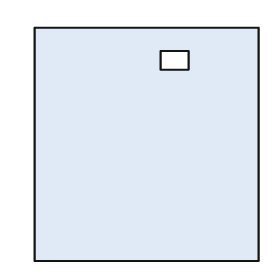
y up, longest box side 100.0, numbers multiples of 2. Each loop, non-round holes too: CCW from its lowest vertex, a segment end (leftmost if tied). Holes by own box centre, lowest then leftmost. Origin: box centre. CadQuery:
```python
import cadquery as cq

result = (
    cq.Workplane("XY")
    .moveTo(-48.0, -50.0)
    .lineTo(48.0, -50.0)
    .lineTo(48.0, 50.0)
    .lineTo(-48.0, 50.0)
    .close()
    .moveTo(6.0, 32.0)
    .lineTo(18.0, 32.0)
    .lineTo(18.0, 40.0)
    .lineTo(6.0, 40.0)
    .close()
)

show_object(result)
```